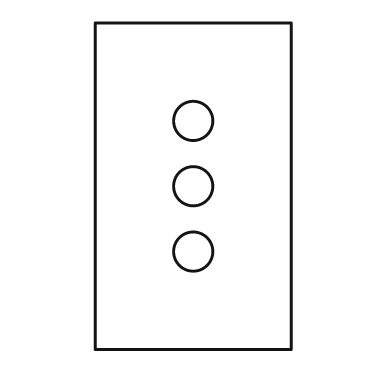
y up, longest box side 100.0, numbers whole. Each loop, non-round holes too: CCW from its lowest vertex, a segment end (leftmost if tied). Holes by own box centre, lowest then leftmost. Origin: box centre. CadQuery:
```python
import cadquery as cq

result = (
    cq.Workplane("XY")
    .moveTo(-30.0, -50.0)
    .lineTo(30.0, -50.0)
    .lineTo(30.0, 50.0)
    .lineTo(-30.0, 50.0)
    .close()
    .moveTo(0.0, -20.0)
    .circle(6.0)
    .moveTo(0.0, 0.0)
    .circle(6.0)
    .moveTo(0.0, 20.0)
    .circle(6.0)
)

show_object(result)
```